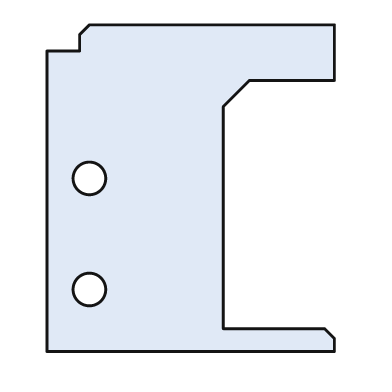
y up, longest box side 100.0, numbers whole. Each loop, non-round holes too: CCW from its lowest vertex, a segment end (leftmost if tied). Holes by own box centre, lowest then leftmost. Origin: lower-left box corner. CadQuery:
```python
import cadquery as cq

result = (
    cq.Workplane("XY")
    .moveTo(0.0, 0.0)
    .lineTo(88.0, 0.0)
    .lineTo(88.0, 4.0)
    .lineTo(85.0, 7.0)
    .lineTo(54.0, 7.0)
    .lineTo(54.0, 75.0)
    .lineTo(62.0, 83.0)
    .lineTo(88.0, 83.0)
    .lineTo(88.0, 100.0)
    .lineTo(13.0, 100.0)
    .lineTo(10.0, 97.0)
    .lineTo(10.0, 92.0)
    .lineTo(0.0, 92.0)
    .close()
    .moveTo(13.0, 19.0)
    .circle(5.0)
    .moveTo(13.0, 53.0)
    .circle(5.0)
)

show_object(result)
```